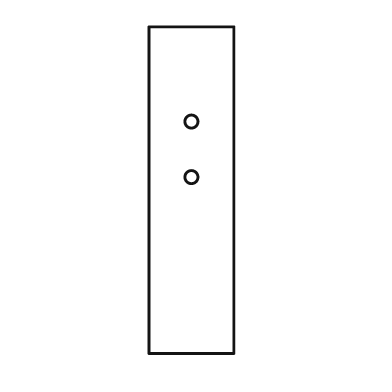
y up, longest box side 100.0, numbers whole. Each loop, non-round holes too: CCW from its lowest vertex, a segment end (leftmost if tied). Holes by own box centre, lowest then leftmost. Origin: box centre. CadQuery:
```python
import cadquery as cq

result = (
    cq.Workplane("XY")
    .moveTo(-13.0, -50.0)
    .lineTo(13.0, -50.0)
    .lineTo(13.0, 50.0)
    .lineTo(-13.0, 50.0)
    .close()
    .moveTo(0.0, 4.0)
    .circle(2.0)
    .moveTo(0.0, 21.0)
    .circle(2.0)
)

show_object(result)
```